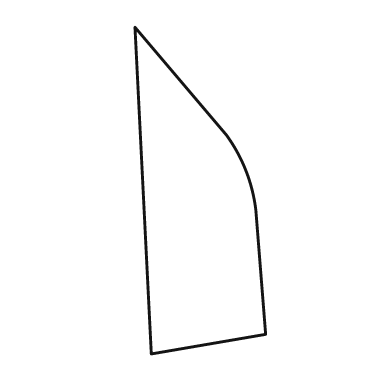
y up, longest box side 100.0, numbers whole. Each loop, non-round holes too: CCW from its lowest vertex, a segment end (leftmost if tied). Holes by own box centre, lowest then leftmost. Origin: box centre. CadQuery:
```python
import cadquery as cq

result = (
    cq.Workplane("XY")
    .moveTo(-15.0, -50.0)
    .lineTo(20.0, -44.0)
    .lineTo(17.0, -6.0)
    .threePointArc((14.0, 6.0), (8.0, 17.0))
    .lineTo(-20.0, 50.0)
    .close()
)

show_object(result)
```